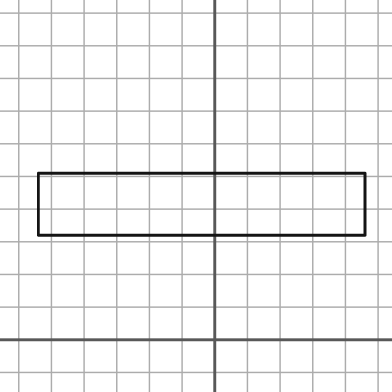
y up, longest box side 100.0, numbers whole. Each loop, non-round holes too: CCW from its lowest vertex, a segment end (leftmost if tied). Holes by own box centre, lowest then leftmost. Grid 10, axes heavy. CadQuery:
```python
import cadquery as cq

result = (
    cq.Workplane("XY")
    .moveTo(-54.0, 32.0)
    .lineTo(46.0, 32.0)
    .lineTo(46.0, 51.0)
    .lineTo(-54.0, 51.0)
    .close()
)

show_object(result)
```